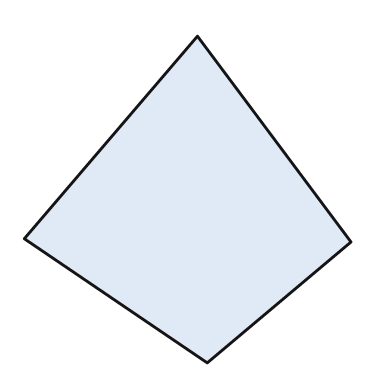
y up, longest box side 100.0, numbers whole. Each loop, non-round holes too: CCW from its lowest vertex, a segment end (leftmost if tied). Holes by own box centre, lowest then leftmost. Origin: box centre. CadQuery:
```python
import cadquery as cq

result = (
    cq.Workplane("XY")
    .moveTo(6.0, -50.0)
    .lineTo(50.0, -13.0)
    .lineTo(3.0, 50.0)
    .lineTo(-50.0, -12.0)
    .close()
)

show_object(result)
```